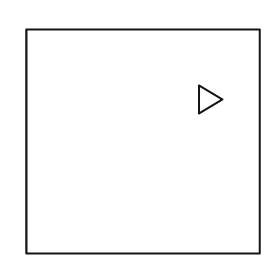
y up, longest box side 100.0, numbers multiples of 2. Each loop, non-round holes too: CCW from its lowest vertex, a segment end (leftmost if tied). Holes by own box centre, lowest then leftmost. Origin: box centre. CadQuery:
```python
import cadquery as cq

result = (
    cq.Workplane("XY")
    .moveTo(-50.0, -48.0)
    .lineTo(50.0, -48.0)
    .lineTo(50.0, 48.0)
    .lineTo(-50.0, 48.0)
    .close()
    .moveTo(24.0, 12.0)
    .lineTo(34.0, 18.0)
    .lineTo(24.0, 24.0)
    .close()
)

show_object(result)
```